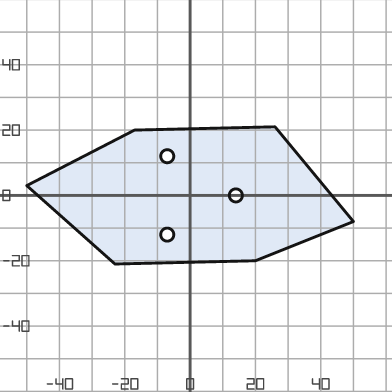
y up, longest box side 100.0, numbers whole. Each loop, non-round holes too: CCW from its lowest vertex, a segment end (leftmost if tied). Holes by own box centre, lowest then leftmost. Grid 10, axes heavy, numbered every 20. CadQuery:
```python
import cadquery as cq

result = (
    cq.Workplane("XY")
    .moveTo(-23.0, -21.0)
    .lineTo(20.0, -20.0)
    .lineTo(50.0, -8.0)
    .lineTo(26.0, 21.0)
    .lineTo(-17.0, 20.0)
    .lineTo(-50.0, 3.0)
    .close()
    .moveTo(-7.0, -12.0)
    .circle(2.0)
    .moveTo(14.0, 0.0)
    .circle(2.0)
    .moveTo(-7.0, 12.0)
    .circle(2.0)
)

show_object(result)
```